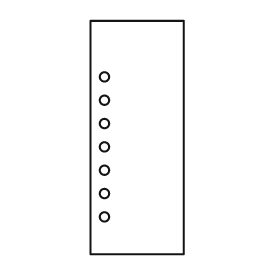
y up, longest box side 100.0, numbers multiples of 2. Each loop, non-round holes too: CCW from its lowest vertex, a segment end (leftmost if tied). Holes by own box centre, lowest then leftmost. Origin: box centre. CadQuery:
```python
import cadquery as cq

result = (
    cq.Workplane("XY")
    .moveTo(-20.0, -50.0)
    .lineTo(20.0, -50.0)
    .lineTo(20.0, 50.0)
    .lineTo(-20.0, 50.0)
    .close()
    .moveTo(-14.0, -34.0)
    .circle(2.0)
    .moveTo(-14.0, -24.0)
    .circle(2.0)
    .moveTo(-14.0, -14.0)
    .circle(2.0)
    .moveTo(-14.0, -4.0)
    .circle(2.0)
    .moveTo(-14.0, 6.0)
    .circle(2.0)
    .moveTo(-14.0, 16.0)
    .circle(2.0)
    .moveTo(-14.0, 26.0)
    .circle(2.0)
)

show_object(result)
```